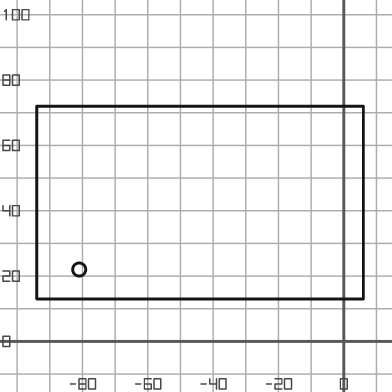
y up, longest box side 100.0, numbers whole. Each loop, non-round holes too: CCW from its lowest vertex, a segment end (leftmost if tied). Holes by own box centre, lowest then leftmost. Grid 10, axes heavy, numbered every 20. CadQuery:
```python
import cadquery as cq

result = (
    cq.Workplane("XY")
    .moveTo(-94.0, 13.0)
    .lineTo(6.0, 13.0)
    .lineTo(6.0, 72.0)
    .lineTo(-94.0, 72.0)
    .close()
    .moveTo(-81.0, 22.0)
    .circle(2.0)
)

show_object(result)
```